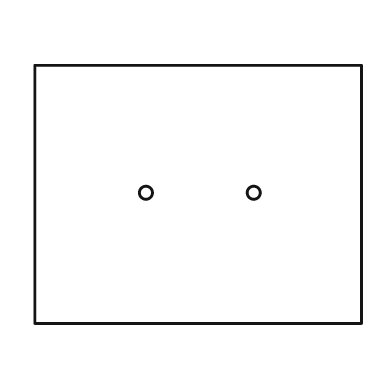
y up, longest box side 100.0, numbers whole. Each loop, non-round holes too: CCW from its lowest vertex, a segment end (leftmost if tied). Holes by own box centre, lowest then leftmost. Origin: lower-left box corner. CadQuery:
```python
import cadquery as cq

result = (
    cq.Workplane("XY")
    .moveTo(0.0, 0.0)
    .lineTo(100.0, 0.0)
    .lineTo(100.0, 79.0)
    .lineTo(0.0, 79.0)
    .close()
    .moveTo(34.0, 40.0)
    .circle(2.0)
    .moveTo(67.0, 40.0)
    .circle(2.0)
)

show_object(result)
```